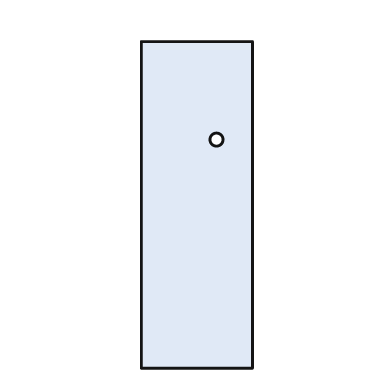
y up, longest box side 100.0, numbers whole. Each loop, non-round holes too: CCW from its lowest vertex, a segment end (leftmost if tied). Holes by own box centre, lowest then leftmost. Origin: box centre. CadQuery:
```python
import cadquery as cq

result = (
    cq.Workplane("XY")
    .moveTo(-17.0, -50.0)
    .lineTo(17.0, -50.0)
    .lineTo(17.0, 50.0)
    .lineTo(-17.0, 50.0)
    .close()
    .moveTo(6.0, 20.0)
    .circle(2.0)
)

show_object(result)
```